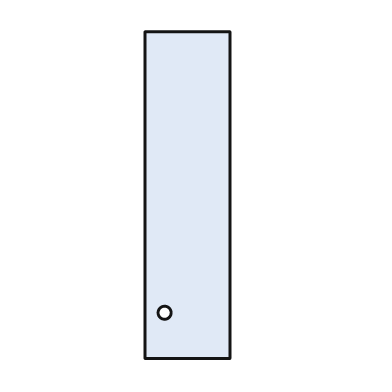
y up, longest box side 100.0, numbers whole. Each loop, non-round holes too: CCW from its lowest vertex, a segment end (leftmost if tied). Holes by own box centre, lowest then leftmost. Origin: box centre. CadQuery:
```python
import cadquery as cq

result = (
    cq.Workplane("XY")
    .moveTo(-13.0, -50.0)
    .lineTo(13.0, -50.0)
    .lineTo(13.0, 50.0)
    .lineTo(-13.0, 50.0)
    .close()
    .moveTo(-7.0, -36.0)
    .circle(2.0)
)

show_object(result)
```